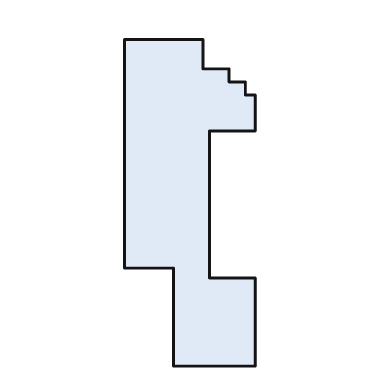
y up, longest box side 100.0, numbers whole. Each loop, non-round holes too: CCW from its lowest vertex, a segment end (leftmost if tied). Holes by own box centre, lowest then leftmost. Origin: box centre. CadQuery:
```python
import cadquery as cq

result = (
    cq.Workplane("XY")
    .moveTo(-5.0, -50.0)
    .lineTo(20.0, -50.0)
    .lineTo(20.0, -23.0)
    .lineTo(6.0, -23.0)
    .lineTo(6.0, 22.0)
    .lineTo(20.0, 22.0)
    .lineTo(20.0, 33.0)
    .lineTo(17.0, 33.0)
    .lineTo(17.0, 37.0)
    .lineTo(12.0, 37.0)
    .lineTo(12.0, 41.0)
    .lineTo(4.0, 41.0)
    .lineTo(4.0, 50.0)
    .lineTo(-20.0, 50.0)
    .lineTo(-20.0, -20.0)
    .lineTo(-5.0, -20.0)
    .close()
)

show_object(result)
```